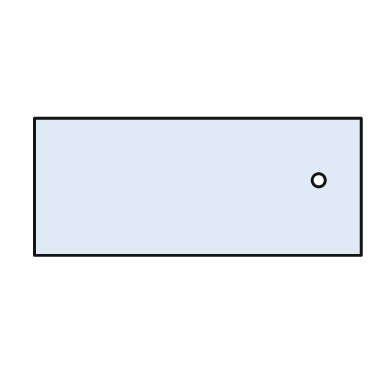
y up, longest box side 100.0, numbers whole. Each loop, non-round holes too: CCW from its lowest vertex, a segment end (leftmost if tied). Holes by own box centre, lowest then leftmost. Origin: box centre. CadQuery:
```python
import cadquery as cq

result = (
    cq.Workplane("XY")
    .moveTo(-50.0, -21.0)
    .lineTo(50.0, -21.0)
    .lineTo(50.0, 21.0)
    .lineTo(-50.0, 21.0)
    .close()
    .moveTo(37.0, 2.0)
    .circle(2.0)
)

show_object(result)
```